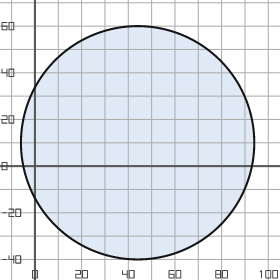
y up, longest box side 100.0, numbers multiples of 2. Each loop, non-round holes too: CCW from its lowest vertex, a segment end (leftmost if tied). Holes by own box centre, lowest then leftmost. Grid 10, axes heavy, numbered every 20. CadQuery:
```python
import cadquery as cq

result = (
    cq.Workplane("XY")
    .moveTo(44.0, 10.0)
    .circle(50.0)
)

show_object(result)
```